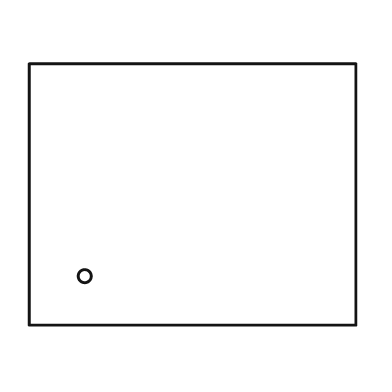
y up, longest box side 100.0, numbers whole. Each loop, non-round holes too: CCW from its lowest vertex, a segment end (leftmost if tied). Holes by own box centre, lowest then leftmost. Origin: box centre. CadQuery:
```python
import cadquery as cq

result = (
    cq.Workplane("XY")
    .moveTo(-50.0, -40.0)
    .lineTo(50.0, -40.0)
    .lineTo(50.0, 40.0)
    .lineTo(-50.0, 40.0)
    .close()
    .moveTo(-33.0, -25.0)
    .circle(2.0)
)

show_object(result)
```